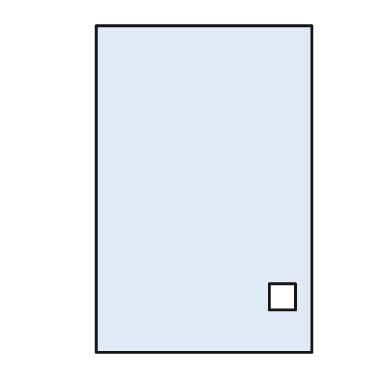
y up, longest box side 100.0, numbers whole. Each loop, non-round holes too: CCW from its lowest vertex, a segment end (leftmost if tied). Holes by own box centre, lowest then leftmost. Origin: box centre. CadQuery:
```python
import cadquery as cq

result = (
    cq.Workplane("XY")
    .moveTo(-33.0, -50.0)
    .lineTo(33.0, -50.0)
    .lineTo(33.0, 50.0)
    .lineTo(-33.0, 50.0)
    .close()
    .moveTo(20.0, -37.0)
    .lineTo(28.0, -37.0)
    .lineTo(28.0, -29.0)
    .lineTo(20.0, -29.0)
    .close()
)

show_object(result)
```